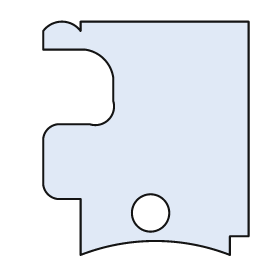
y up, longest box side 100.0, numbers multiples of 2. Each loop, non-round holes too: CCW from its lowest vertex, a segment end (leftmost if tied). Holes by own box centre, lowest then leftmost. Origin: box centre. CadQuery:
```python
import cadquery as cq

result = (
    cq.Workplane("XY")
    .moveTo(-28.0, -50.0)
    .threePointArc((4.0, -44.0), (36.0, -50.0))
    .lineTo(36.0, -42.0)
    .lineTo(44.0, -42.0)
    .lineTo(44.0, 50.0)
    .lineTo(-28.0, 50.0)
    .lineTo(-28.0, 46.0)
    .threePointArc((-36.0, 50.0), (-44.0, 46.0))
    .lineTo(-44.0, 38.0)
    .lineTo(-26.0, 38.0)
    .threePointArc((-18.0, 34.0), (-14.0, 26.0))
    .lineTo(-14.0, 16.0)
    .threePointArc((-16.0, 8.0), (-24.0, 6.0))
    .lineTo(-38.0, 6.0)
    .threePointArc((-42.0, 4.0), (-44.0, 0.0))
    .lineTo(-44.0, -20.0)
    .threePointArc((-42.0, -24.0), (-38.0, -26.0))
    .lineTo(-28.0, -26.0)
    .close()
    .moveTo(2.0, -32.0)
    .circle(8.0)
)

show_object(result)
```